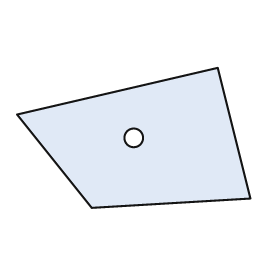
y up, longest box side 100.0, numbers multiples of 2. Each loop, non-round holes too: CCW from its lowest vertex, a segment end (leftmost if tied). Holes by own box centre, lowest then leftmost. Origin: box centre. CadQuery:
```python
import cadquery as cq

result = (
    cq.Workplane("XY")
    .moveTo(-18.0, -30.0)
    .lineTo(50.0, -26.0)
    .lineTo(36.0, 30.0)
    .lineTo(-50.0, 10.0)
    .close()
    .moveTo(0.0, 0.0)
    .circle(4.0)
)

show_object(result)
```